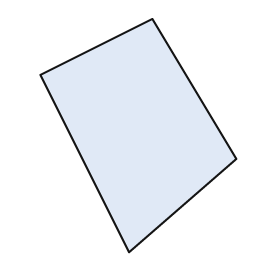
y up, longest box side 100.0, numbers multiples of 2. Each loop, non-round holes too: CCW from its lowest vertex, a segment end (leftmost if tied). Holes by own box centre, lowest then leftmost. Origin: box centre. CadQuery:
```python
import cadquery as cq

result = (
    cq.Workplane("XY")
    .moveTo(-4.0, -50.0)
    .lineTo(42.0, -10.0)
    .lineTo(6.0, 50.0)
    .lineTo(-42.0, 26.0)
    .close()
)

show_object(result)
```